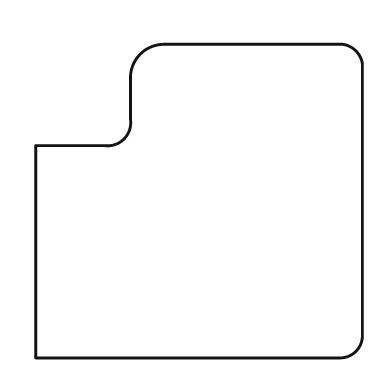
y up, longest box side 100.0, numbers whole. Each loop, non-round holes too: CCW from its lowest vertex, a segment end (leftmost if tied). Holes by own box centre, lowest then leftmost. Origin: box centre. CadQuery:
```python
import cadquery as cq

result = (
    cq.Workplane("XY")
    .moveTo(-50.0, -48.0)
    .lineTo(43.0, -48.0)
    .threePointArc((48.0, -46.0), (50.0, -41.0))
    .lineTo(50.0, 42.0)
    .threePointArc((48.0, 46.0), (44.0, 48.0))
    .lineTo(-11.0, 48.0)
    .threePointArc((-18.0, 45.0), (-21.0, 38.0))
    .lineTo(-21.0, 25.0)
    .threePointArc((-23.0, 19.0), (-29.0, 17.0))
    .lineTo(-50.0, 17.0)
    .close()
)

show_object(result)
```